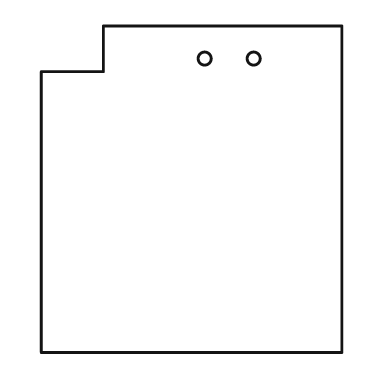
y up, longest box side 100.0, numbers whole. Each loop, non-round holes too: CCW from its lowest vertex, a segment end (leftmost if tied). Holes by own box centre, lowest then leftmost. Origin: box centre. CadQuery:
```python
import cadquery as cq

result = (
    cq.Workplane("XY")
    .moveTo(-46.0, -50.0)
    .lineTo(46.0, -50.0)
    .lineTo(46.0, 50.0)
    .lineTo(-27.0, 50.0)
    .lineTo(-27.0, 36.0)
    .lineTo(-46.0, 36.0)
    .close()
    .moveTo(4.0, 40.0)
    .circle(2.0)
    .moveTo(19.0, 40.0)
    .circle(2.0)
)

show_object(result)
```